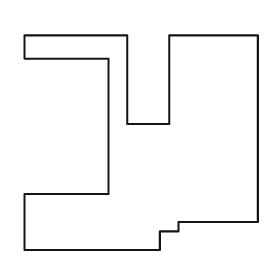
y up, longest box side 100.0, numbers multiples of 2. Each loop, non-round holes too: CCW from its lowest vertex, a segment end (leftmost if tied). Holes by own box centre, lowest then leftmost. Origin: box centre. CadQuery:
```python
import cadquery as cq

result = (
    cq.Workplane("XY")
    .moveTo(-50.0, -46.0)
    .lineTo(8.0, -46.0)
    .lineTo(8.0, -38.0)
    .lineTo(16.0, -38.0)
    .lineTo(16.0, -34.0)
    .lineTo(50.0, -34.0)
    .lineTo(50.0, 46.0)
    .lineTo(12.0, 46.0)
    .lineTo(12.0, 8.0)
    .lineTo(-6.0, 8.0)
    .lineTo(-6.0, 46.0)
    .lineTo(-50.0, 46.0)
    .lineTo(-50.0, 36.0)
    .lineTo(-14.0, 36.0)
    .lineTo(-14.0, -22.0)
    .lineTo(-50.0, -22.0)
    .close()
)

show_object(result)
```